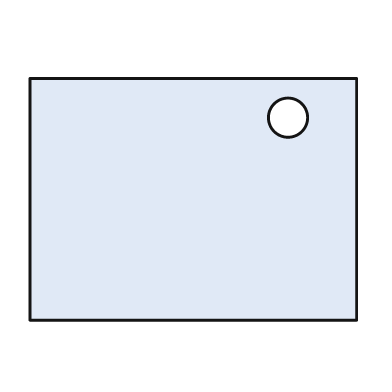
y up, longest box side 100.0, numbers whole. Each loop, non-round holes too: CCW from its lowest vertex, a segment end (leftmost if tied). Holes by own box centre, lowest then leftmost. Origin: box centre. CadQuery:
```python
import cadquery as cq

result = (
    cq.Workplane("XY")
    .moveTo(-50.0, -37.0)
    .lineTo(50.0, -37.0)
    .lineTo(50.0, 37.0)
    .lineTo(-50.0, 37.0)
    .close()
    .moveTo(29.0, 25.0)
    .circle(6.0)
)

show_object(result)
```